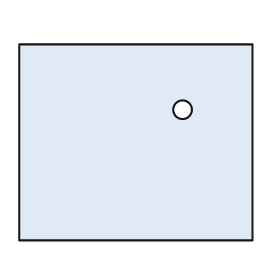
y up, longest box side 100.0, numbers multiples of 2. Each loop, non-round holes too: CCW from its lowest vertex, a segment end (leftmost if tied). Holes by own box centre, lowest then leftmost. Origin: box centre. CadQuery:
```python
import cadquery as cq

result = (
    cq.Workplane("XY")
    .moveTo(-50.0, -42.0)
    .lineTo(50.0, -42.0)
    .lineTo(50.0, 42.0)
    .lineTo(-50.0, 42.0)
    .close()
    .moveTo(20.0, 14.0)
    .circle(4.0)
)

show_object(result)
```